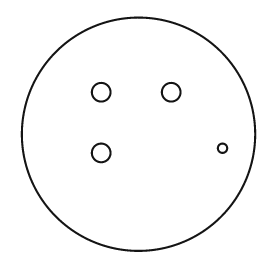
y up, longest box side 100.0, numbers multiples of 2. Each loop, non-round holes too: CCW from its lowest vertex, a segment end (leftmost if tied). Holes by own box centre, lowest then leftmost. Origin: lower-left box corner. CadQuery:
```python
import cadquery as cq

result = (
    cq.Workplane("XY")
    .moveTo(50.0, 50.0)
    .circle(50.0)
    .moveTo(34.0, 42.0)
    .circle(4.0)
    .moveTo(86.0, 44.0)
    .circle(2.0)
    .moveTo(34.0, 68.0)
    .circle(4.0)
    .moveTo(64.0, 68.0)
    .circle(4.0)
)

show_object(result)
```